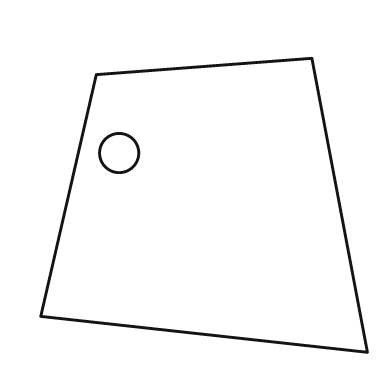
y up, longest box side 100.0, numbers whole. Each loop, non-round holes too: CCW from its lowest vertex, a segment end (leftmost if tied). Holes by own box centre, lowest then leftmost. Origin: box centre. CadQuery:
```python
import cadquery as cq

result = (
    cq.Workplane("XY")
    .moveTo(50.0, -45.0)
    .lineTo(33.0, 45.0)
    .lineTo(-33.0, 40.0)
    .lineTo(-50.0, -34.0)
    .close()
    .moveTo(-26.0, 16.0)
    .circle(6.0)
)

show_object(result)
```